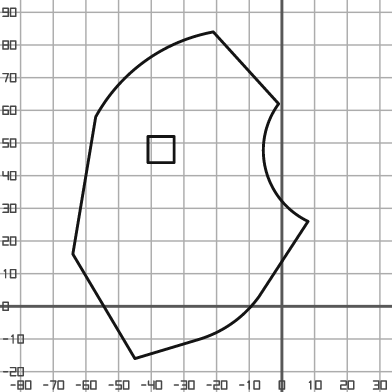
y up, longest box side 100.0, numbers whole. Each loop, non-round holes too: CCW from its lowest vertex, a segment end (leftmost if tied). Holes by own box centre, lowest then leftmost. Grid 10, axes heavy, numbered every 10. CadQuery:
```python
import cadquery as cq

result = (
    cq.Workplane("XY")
    .moveTo(-45.0, -16.0)
    .lineTo(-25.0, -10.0)
    .threePointArc((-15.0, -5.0), (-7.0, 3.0))
    .lineTo(8.0, 26.0)
    .threePointArc((-5.0, 42.0), (-1.0, 62.0))
    .lineTo(-21.0, 84.0)
    .threePointArc((-42.0, 75.0), (-57.0, 58.0))
    .lineTo(-64.0, 16.0)
    .close()
    .moveTo(-41.0, 44.0)
    .lineTo(-33.0, 44.0)
    .lineTo(-33.0, 52.0)
    .lineTo(-41.0, 52.0)
    .close()
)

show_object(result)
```